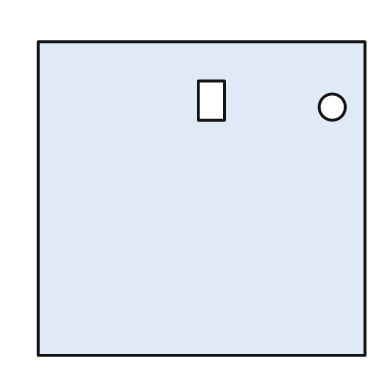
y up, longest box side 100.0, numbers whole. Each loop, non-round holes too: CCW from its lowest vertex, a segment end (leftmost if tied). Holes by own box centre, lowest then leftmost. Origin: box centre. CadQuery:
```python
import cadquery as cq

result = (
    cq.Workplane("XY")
    .moveTo(-50.0, -48.0)
    .lineTo(50.0, -48.0)
    .lineTo(50.0, 48.0)
    .lineTo(-50.0, 48.0)
    .close()
    .moveTo(40.0, 28.0)
    .circle(4.0)
    .moveTo(-1.0, 24.0)
    .lineTo(7.0, 24.0)
    .lineTo(7.0, 36.0)
    .lineTo(-1.0, 36.0)
    .close()
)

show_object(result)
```